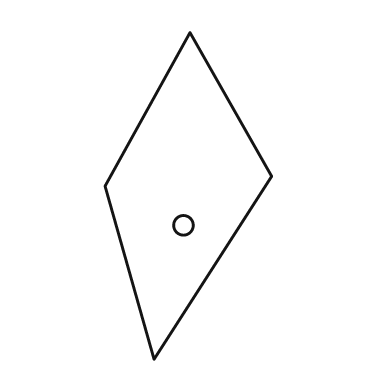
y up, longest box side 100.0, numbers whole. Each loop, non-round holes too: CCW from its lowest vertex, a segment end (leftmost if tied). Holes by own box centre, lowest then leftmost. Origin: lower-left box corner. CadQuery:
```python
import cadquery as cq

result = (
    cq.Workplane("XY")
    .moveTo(15.0, 0.0)
    .lineTo(51.0, 56.0)
    .lineTo(26.0, 100.0)
    .lineTo(0.0, 53.0)
    .close()
    .moveTo(24.0, 41.0)
    .circle(3.0)
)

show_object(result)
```